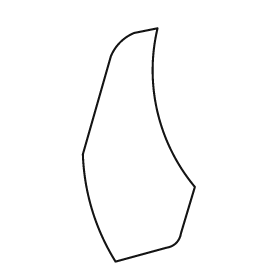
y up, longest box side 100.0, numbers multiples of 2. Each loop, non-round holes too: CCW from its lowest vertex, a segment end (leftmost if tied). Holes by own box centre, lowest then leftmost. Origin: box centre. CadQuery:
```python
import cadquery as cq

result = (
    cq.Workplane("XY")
    .moveTo(-10.0, -50.0)
    .lineTo(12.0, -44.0)
    .threePointArc((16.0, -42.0), (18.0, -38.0))
    .lineTo(24.0, -18.0)
    .threePointArc((8.0, 14.0), (8.0, 50.0))
    .lineTo(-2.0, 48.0)
    .threePointArc((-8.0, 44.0), (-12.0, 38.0))
    .lineTo(-24.0, -4.0)
    .threePointArc((-20.0, -28.0), (-10.0, -50.0))
    .close()
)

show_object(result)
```